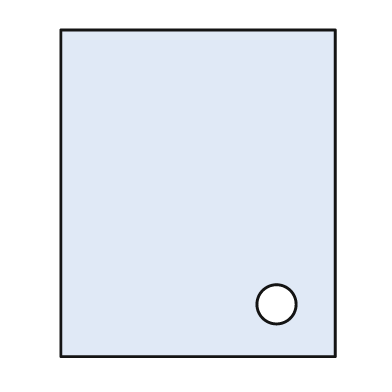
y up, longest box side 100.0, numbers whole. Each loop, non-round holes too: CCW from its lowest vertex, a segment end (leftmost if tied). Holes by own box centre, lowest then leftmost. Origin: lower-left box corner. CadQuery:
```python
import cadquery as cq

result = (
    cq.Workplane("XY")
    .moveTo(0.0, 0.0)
    .lineTo(84.0, 0.0)
    .lineTo(84.0, 100.0)
    .lineTo(0.0, 100.0)
    .close()
    .moveTo(66.0, 16.0)
    .circle(6.0)
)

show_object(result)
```